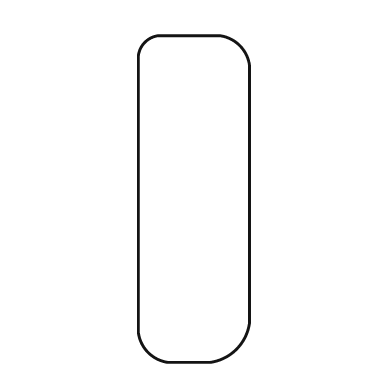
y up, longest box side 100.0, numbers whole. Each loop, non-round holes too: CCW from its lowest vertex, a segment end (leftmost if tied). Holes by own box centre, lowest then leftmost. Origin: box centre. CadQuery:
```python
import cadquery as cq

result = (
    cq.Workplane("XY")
    .moveTo(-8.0, -50.0)
    .lineTo(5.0, -50.0)
    .threePointArc((13.0, -46.0), (17.0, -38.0))
    .lineTo(17.0, 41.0)
    .threePointArc((14.0, 47.0), (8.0, 50.0))
    .lineTo(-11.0, 50.0)
    .threePointArc((-15.0, 48.0), (-17.0, 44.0))
    .lineTo(-17.0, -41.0)
    .threePointArc((-14.0, -47.0), (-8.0, -50.0))
    .close()
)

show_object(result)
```